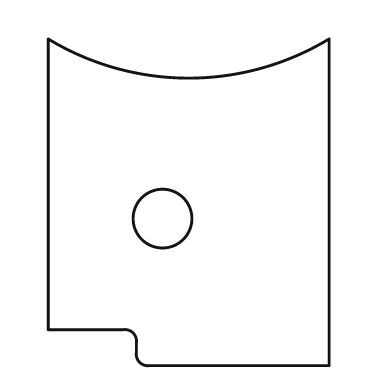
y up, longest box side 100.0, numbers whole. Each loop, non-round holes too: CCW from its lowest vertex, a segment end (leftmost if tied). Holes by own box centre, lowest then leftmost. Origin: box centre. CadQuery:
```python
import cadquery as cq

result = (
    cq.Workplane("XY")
    .moveTo(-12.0, -50.0)
    .lineTo(43.0, -50.0)
    .lineTo(43.0, 50.0)
    .threePointArc((0.0, 38.0), (-43.0, 50.0))
    .lineTo(-43.0, -39.0)
    .lineTo(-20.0, -39.0)
    .threePointArc((-17.0, -40.0), (-16.0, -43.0))
    .lineTo(-16.0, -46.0)
    .threePointArc((-15.0, -49.0), (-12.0, -50.0))
    .close()
    .moveTo(-8.0, -5.0)
    .circle(9.0)
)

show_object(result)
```